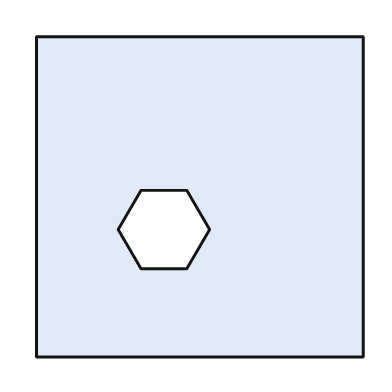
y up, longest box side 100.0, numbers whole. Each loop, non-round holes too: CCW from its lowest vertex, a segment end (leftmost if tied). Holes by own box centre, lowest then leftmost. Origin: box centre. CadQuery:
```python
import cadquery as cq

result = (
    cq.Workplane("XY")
    .moveTo(-50.0, -49.0)
    .lineTo(50.0, -49.0)
    .lineTo(50.0, 49.0)
    .lineTo(-50.0, 49.0)
    .close()
    .moveTo(-18.0, -22.0)
    .lineTo(-4.0, -22.0)
    .lineTo(3.0, -10.0)
    .lineTo(-4.0, 2.0)
    .lineTo(-18.0, 2.0)
    .lineTo(-25.0, -10.0)
    .close()
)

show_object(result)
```